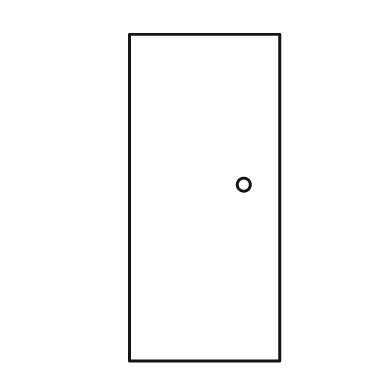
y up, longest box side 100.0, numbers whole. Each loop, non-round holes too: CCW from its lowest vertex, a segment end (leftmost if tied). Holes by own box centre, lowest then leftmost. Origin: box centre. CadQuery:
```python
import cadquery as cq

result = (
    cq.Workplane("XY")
    .moveTo(-23.0, -50.0)
    .lineTo(23.0, -50.0)
    .lineTo(23.0, 50.0)
    .lineTo(-23.0, 50.0)
    .close()
    .moveTo(12.0, 4.0)
    .circle(2.0)
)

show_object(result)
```